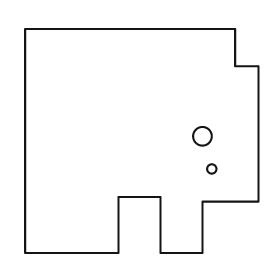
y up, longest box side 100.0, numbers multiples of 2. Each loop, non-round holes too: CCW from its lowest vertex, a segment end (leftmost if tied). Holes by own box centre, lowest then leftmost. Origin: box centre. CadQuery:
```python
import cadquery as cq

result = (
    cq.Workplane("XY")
    .moveTo(-50.0, -48.0)
    .lineTo(-10.0, -48.0)
    .lineTo(-10.0, -24.0)
    .lineTo(8.0, -24.0)
    .lineTo(8.0, -48.0)
    .lineTo(26.0, -48.0)
    .lineTo(26.0, -26.0)
    .lineTo(50.0, -26.0)
    .lineTo(50.0, 32.0)
    .lineTo(40.0, 32.0)
    .lineTo(40.0, 48.0)
    .lineTo(-50.0, 48.0)
    .close()
    .moveTo(30.0, -12.0)
    .circle(2.0)
    .moveTo(26.0, 2.0)
    .circle(4.0)
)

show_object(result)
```